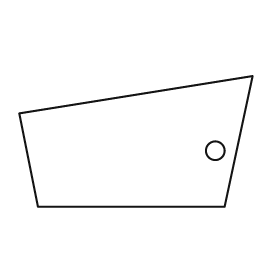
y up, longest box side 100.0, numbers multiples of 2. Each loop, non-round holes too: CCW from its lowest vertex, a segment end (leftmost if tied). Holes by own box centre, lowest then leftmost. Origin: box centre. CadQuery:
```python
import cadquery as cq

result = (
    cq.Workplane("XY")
    .moveTo(-42.0, -28.0)
    .lineTo(38.0, -28.0)
    .lineTo(50.0, 28.0)
    .lineTo(-50.0, 12.0)
    .close()
    .moveTo(34.0, -4.0)
    .circle(4.0)
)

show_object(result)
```